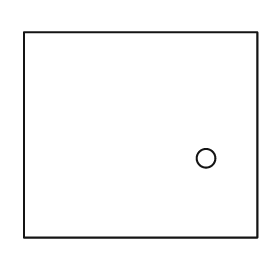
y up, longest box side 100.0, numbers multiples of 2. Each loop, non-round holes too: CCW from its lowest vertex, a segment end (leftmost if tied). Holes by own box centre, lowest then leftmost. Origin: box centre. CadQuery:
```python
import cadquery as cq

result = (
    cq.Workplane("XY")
    .moveTo(-50.0, -44.0)
    .lineTo(50.0, -44.0)
    .lineTo(50.0, 44.0)
    .lineTo(-50.0, 44.0)
    .close()
    .moveTo(28.0, -10.0)
    .circle(4.0)
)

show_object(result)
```